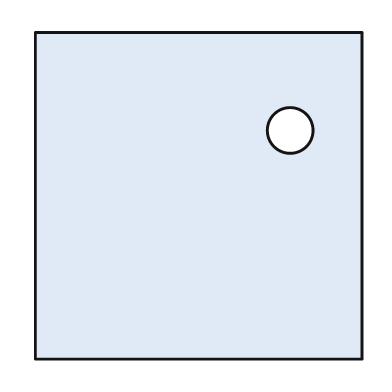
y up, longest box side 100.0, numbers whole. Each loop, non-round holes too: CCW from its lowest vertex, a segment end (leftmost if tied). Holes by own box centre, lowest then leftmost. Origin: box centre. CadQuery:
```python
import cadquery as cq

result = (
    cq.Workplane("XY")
    .moveTo(-50.0, -50.0)
    .lineTo(50.0, -50.0)
    .lineTo(50.0, 50.0)
    .lineTo(-50.0, 50.0)
    .close()
    .moveTo(28.0, 20.0)
    .circle(7.0)
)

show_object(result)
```